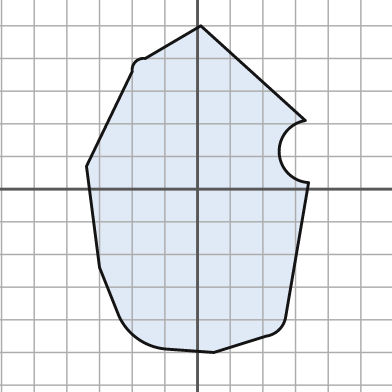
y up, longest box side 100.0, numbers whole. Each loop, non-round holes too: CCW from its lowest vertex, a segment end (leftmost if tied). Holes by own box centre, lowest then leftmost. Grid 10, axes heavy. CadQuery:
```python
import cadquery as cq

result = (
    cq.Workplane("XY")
    .moveTo(5.0, -50.0)
    .lineTo(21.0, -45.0)
    .threePointArc((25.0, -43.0), (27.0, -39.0))
    .lineTo(34.0, 2.0)
    .threePointArc((25.0, 11.0), (33.0, 21.0))
    .lineTo(1.0, 50.0)
    .lineTo(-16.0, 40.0)
    .threePointArc((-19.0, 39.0), (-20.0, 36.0))
    .lineTo(-34.0, 7.0)
    .lineTo(-30.0, -24.0)
    .lineTo(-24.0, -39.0)
    .threePointArc((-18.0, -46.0), (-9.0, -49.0))
    .close()
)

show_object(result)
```